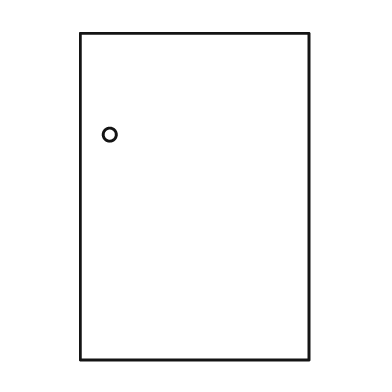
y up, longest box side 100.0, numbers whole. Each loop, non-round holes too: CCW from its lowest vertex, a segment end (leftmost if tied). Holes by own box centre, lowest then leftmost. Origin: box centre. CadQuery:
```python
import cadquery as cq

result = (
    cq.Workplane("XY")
    .moveTo(-35.0, -50.0)
    .lineTo(35.0, -50.0)
    .lineTo(35.0, 50.0)
    .lineTo(-35.0, 50.0)
    .close()
    .moveTo(-26.0, 19.0)
    .circle(2.0)
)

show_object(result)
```